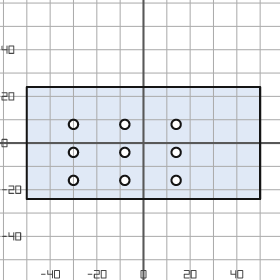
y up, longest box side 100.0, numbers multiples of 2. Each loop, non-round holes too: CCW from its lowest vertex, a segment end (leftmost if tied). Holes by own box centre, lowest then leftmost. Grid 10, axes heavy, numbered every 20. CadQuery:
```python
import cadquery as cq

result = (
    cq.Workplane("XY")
    .moveTo(-50.0, -24.0)
    .lineTo(50.0, -24.0)
    .lineTo(50.0, 24.0)
    .lineTo(-50.0, 24.0)
    .close()
    .moveTo(-30.0, -16.0)
    .circle(2.0)
    .moveTo(-8.0, -16.0)
    .circle(2.0)
    .moveTo(14.0, -16.0)
    .circle(2.0)
    .moveTo(-30.0, -4.0)
    .circle(2.0)
    .moveTo(-8.0, -4.0)
    .circle(2.0)
    .moveTo(14.0, -4.0)
    .circle(2.0)
    .moveTo(-30.0, 8.0)
    .circle(2.0)
    .moveTo(-8.0, 8.0)
    .circle(2.0)
    .moveTo(14.0, 8.0)
    .circle(2.0)
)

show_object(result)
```